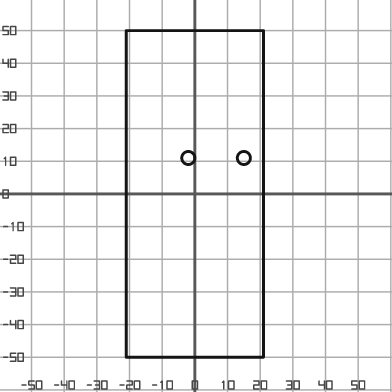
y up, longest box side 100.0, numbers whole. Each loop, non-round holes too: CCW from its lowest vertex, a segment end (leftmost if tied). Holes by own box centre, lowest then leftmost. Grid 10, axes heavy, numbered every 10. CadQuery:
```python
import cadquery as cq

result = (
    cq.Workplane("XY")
    .moveTo(-21.0, -50.0)
    .lineTo(21.0, -50.0)
    .lineTo(21.0, 50.0)
    .lineTo(-21.0, 50.0)
    .close()
    .moveTo(-2.0, 11.0)
    .circle(2.0)
    .moveTo(15.0, 11.0)
    .circle(2.0)
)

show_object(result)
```